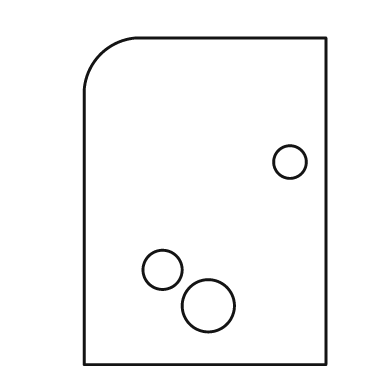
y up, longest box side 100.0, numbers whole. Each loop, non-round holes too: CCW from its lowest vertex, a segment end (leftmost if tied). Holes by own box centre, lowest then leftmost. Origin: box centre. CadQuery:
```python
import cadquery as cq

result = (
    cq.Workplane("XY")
    .moveTo(-37.0, -50.0)
    .lineTo(37.0, -50.0)
    .lineTo(37.0, 50.0)
    .lineTo(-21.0, 50.0)
    .threePointArc((-32.0, 45.0), (-37.0, 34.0))
    .close()
    .moveTo(1.0, -32.0)
    .circle(8.0)
    .moveTo(-13.0, -21.0)
    .circle(6.0)
    .moveTo(26.0, 12.0)
    .circle(5.0)
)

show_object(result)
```